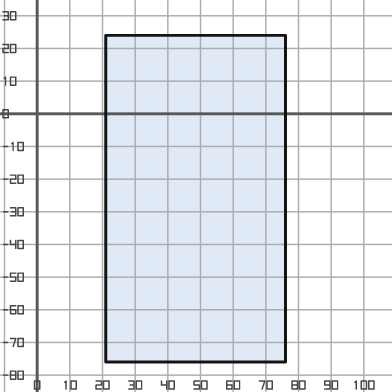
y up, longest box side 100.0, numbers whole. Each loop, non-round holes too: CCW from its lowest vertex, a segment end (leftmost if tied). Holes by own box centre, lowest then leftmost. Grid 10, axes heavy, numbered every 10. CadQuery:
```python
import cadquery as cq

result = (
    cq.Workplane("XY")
    .moveTo(21.0, -76.0)
    .lineTo(76.0, -76.0)
    .lineTo(76.0, 24.0)
    .lineTo(21.0, 24.0)
    .close()
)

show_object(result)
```